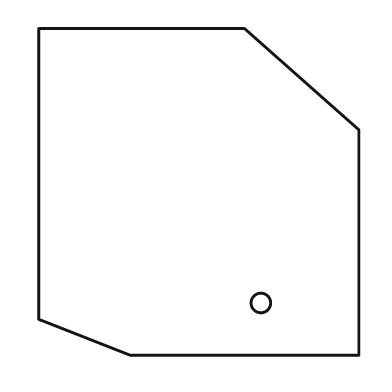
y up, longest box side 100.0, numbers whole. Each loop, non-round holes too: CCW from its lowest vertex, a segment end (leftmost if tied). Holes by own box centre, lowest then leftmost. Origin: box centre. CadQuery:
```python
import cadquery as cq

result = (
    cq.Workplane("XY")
    .moveTo(-21.0, -50.0)
    .lineTo(49.0, -50.0)
    .lineTo(49.0, 19.0)
    .lineTo(14.0, 50.0)
    .lineTo(-49.0, 50.0)
    .lineTo(-49.0, -39.0)
    .close()
    .moveTo(19.0, -34.0)
    .circle(3.0)
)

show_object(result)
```